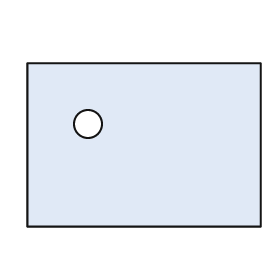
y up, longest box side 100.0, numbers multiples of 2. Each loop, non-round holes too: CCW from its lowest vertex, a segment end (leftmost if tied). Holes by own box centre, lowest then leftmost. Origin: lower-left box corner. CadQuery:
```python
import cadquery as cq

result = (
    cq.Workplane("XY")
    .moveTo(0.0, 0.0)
    .lineTo(100.0, 0.0)
    .lineTo(100.0, 70.0)
    .lineTo(0.0, 70.0)
    .close()
    .moveTo(26.0, 44.0)
    .circle(6.0)
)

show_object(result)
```